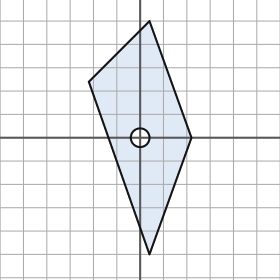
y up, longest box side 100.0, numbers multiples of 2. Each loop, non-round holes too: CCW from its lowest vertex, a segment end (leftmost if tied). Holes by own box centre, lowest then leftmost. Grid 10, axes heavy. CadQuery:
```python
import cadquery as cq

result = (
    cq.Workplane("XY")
    .moveTo(4.0, -50.0)
    .lineTo(22.0, 0.0)
    .lineTo(4.0, 50.0)
    .lineTo(-22.0, 24.0)
    .close()
    .moveTo(0.0, 0.0)
    .circle(4.0)
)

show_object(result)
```